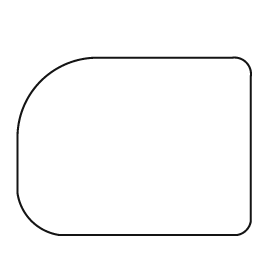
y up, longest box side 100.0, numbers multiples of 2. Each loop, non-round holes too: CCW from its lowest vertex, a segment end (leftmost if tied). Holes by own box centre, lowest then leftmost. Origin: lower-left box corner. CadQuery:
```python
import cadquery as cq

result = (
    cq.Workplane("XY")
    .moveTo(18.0, 0.0)
    .lineTo(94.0, 0.0)
    .threePointArc((98.0, 2.0), (100.0, 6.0))
    .lineTo(100.0, 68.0)
    .threePointArc((98.0, 74.0), (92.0, 76.0))
    .lineTo(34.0, 76.0)
    .threePointArc((10.0, 66.0), (0.0, 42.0))
    .lineTo(0.0, 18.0)
    .threePointArc((6.0, 6.0), (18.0, 0.0))
    .close()
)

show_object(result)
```